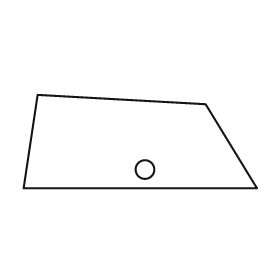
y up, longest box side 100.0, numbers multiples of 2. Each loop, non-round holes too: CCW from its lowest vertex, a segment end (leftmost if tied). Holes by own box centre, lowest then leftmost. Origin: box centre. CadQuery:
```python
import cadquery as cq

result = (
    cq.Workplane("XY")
    .moveTo(-50.0, -20.0)
    .lineTo(50.0, -20.0)
    .lineTo(28.0, 16.0)
    .lineTo(-44.0, 20.0)
    .close()
    .moveTo(2.0, -12.0)
    .circle(4.0)
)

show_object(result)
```